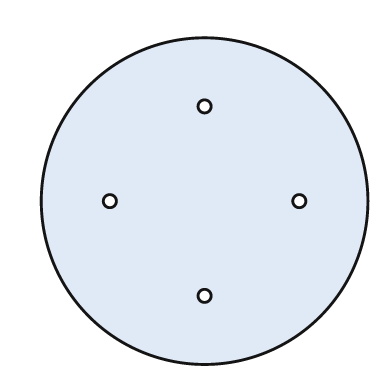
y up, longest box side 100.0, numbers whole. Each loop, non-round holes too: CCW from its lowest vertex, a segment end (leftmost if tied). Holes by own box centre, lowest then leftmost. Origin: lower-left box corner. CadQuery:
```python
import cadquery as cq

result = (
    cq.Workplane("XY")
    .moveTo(50.0, 50.0)
    .circle(50.0)
    .moveTo(50.0, 21.0)
    .circle(2.0)
    .moveTo(21.0, 50.0)
    .circle(2.0)
    .moveTo(79.0, 50.0)
    .circle(2.0)
    .moveTo(50.0, 79.0)
    .circle(2.0)
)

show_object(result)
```